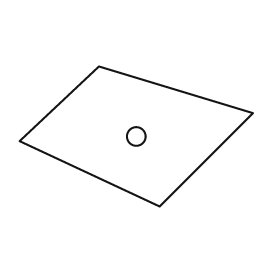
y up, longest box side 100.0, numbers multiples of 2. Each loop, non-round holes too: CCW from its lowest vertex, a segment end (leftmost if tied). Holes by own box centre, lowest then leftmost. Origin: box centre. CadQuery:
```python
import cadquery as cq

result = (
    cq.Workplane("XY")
    .moveTo(10.0, -30.0)
    .lineTo(50.0, 10.0)
    .lineTo(-16.0, 30.0)
    .lineTo(-50.0, -2.0)
    .close()
    .moveTo(0.0, 0.0)
    .circle(4.0)
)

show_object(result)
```